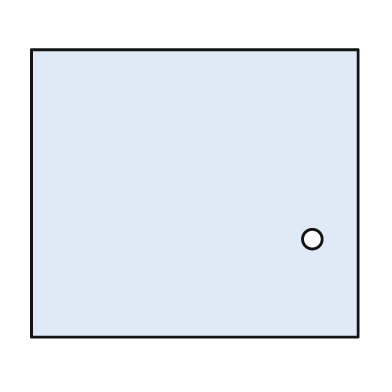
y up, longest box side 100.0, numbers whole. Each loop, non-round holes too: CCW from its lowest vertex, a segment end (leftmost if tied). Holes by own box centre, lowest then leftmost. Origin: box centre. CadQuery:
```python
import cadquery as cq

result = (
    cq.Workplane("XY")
    .moveTo(-50.0, -44.0)
    .lineTo(50.0, -44.0)
    .lineTo(50.0, 44.0)
    .lineTo(-50.0, 44.0)
    .close()
    .moveTo(36.0, -14.0)
    .circle(3.0)
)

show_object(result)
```